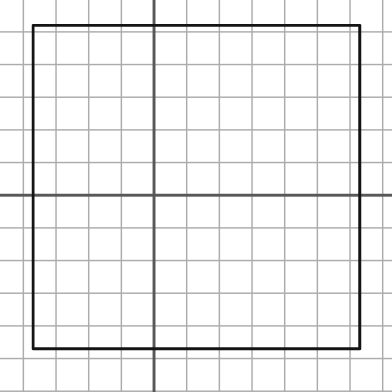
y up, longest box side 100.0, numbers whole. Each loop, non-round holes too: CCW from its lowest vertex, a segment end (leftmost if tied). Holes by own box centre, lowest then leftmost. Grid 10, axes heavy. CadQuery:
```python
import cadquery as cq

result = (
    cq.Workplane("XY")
    .moveTo(-37.0, -47.0)
    .lineTo(63.0, -47.0)
    .lineTo(63.0, 52.0)
    .lineTo(-37.0, 52.0)
    .close()
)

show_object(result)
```